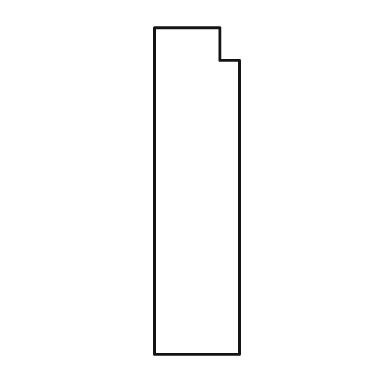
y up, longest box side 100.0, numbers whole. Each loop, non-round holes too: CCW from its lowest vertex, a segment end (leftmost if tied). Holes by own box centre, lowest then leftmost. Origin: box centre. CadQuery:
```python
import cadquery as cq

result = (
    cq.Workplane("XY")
    .moveTo(-13.0, -50.0)
    .lineTo(13.0, -50.0)
    .lineTo(13.0, 40.0)
    .lineTo(7.0, 40.0)
    .lineTo(7.0, 50.0)
    .lineTo(-13.0, 50.0)
    .close()
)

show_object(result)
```